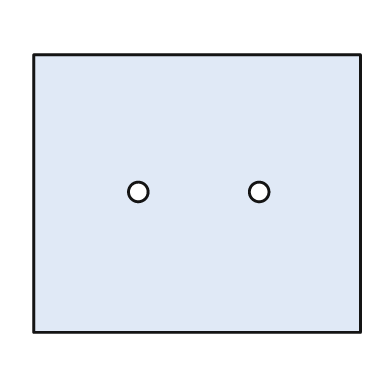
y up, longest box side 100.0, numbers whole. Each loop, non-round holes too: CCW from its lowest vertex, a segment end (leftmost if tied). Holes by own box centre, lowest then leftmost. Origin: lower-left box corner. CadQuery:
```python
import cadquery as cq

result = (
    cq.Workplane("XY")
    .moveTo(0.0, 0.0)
    .lineTo(100.0, 0.0)
    .lineTo(100.0, 85.0)
    .lineTo(0.0, 85.0)
    .close()
    .moveTo(32.0, 43.0)
    .circle(3.0)
    .moveTo(69.0, 43.0)
    .circle(3.0)
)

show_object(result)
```